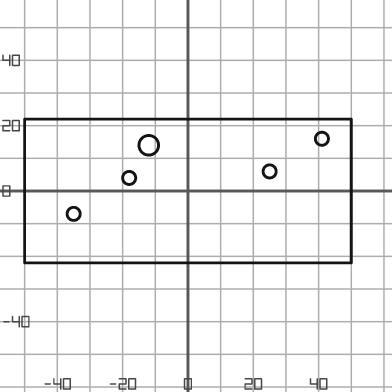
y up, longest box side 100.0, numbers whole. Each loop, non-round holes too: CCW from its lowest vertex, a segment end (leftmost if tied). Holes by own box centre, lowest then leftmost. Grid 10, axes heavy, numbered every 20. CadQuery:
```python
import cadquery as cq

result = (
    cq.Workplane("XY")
    .moveTo(-50.0, -22.0)
    .lineTo(50.0, -22.0)
    .lineTo(50.0, 22.0)
    .lineTo(-50.0, 22.0)
    .close()
    .moveTo(-35.0, -7.0)
    .circle(2.0)
    .moveTo(-18.0, 4.0)
    .circle(2.0)
    .moveTo(25.0, 6.0)
    .circle(2.0)
    .moveTo(-12.0, 14.0)
    .circle(3.0)
    .moveTo(41.0, 16.0)
    .circle(2.0)
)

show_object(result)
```